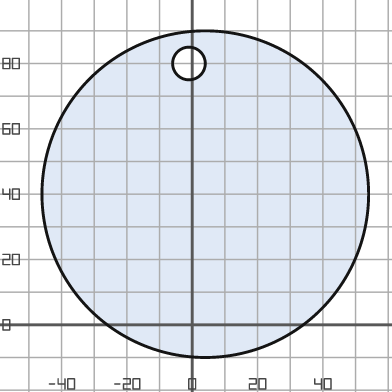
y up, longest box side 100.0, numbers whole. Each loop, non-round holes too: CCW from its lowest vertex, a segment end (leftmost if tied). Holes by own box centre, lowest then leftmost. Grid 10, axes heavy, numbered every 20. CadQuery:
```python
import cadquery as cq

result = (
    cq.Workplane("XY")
    .moveTo(4.0, 40.0)
    .circle(50.0)
    .moveTo(-1.0, 80.0)
    .circle(5.0)
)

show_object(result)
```